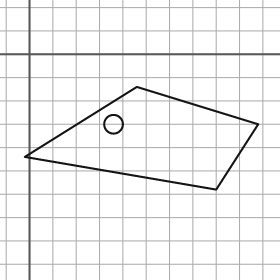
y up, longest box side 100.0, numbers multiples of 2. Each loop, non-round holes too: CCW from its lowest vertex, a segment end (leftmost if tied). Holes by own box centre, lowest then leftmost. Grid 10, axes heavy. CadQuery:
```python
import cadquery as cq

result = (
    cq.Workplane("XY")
    .moveTo(80.0, -58.0)
    .lineTo(98.0, -30.0)
    .lineTo(46.0, -14.0)
    .lineTo(-2.0, -44.0)
    .close()
    .moveTo(36.0, -30.0)
    .circle(4.0)
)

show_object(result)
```